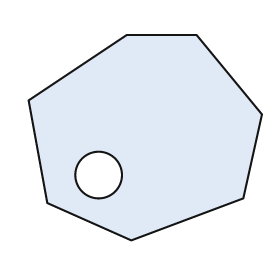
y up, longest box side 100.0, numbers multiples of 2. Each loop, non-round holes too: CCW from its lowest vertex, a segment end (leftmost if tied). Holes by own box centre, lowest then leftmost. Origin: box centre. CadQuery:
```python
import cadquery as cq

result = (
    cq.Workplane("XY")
    .moveTo(-6.0, -44.0)
    .lineTo(42.0, -26.0)
    .lineTo(50.0, 10.0)
    .lineTo(22.0, 44.0)
    .lineTo(-8.0, 44.0)
    .lineTo(-50.0, 16.0)
    .lineTo(-42.0, -28.0)
    .close()
    .moveTo(-20.0, -16.0)
    .circle(10.0)
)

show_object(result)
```